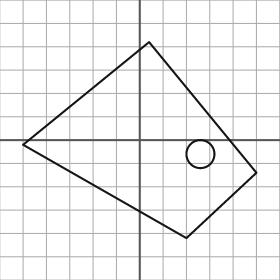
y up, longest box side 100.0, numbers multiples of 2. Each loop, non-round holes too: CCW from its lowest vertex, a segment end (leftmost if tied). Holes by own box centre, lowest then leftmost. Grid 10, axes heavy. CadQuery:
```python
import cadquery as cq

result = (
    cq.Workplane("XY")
    .moveTo(20.0, -42.0)
    .lineTo(50.0, -14.0)
    .lineTo(4.0, 42.0)
    .lineTo(-50.0, -2.0)
    .close()
    .moveTo(26.0, -6.0)
    .circle(6.0)
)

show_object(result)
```